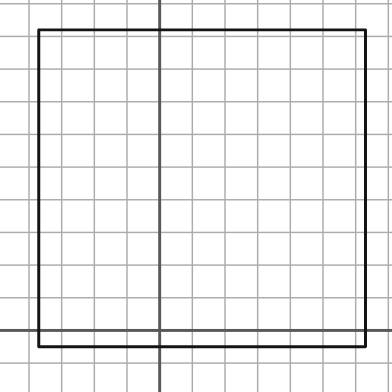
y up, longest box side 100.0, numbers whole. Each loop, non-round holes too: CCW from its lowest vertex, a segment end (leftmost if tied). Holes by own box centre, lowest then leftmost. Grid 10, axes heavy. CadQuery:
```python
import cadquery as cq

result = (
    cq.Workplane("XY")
    .moveTo(-37.0, -5.0)
    .lineTo(63.0, -5.0)
    .lineTo(63.0, 92.0)
    .lineTo(-37.0, 92.0)
    .close()
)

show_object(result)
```